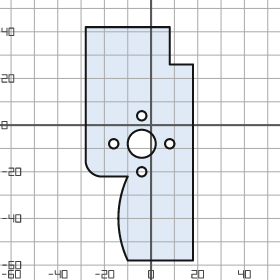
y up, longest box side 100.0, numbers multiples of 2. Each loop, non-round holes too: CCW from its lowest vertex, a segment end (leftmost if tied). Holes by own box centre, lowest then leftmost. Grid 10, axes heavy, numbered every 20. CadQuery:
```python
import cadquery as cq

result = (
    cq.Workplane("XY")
    .moveTo(-10.0, -58.0)
    .lineTo(18.0, -58.0)
    .lineTo(18.0, 26.0)
    .lineTo(8.0, 26.0)
    .lineTo(8.0, 42.0)
    .lineTo(-28.0, 42.0)
    .lineTo(-28.0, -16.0)
    .threePointArc((-26.0, -20.0), (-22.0, -22.0))
    .lineTo(-10.0, -22.0)
    .threePointArc((-14.0, -40.0), (-10.0, -58.0))
    .close()
    .moveTo(-4.0, -20.0)
    .circle(2.0)
    .moveTo(-16.0, -8.0)
    .circle(2.0)
    .moveTo(-4.0, -8.0)
    .circle(6.0)
    .moveTo(8.0, -8.0)
    .circle(2.0)
    .moveTo(-4.0, 4.0)
    .circle(2.0)
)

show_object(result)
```